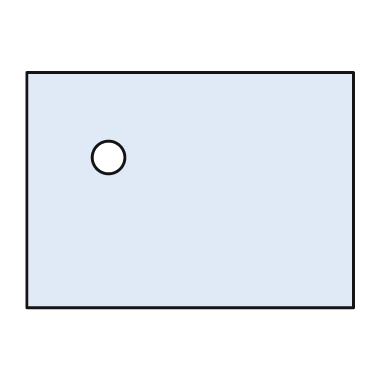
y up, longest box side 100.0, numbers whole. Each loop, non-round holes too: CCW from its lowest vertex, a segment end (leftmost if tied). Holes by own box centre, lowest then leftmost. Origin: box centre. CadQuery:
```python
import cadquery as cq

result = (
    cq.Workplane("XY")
    .moveTo(-50.0, -36.0)
    .lineTo(50.0, -36.0)
    .lineTo(50.0, 36.0)
    .lineTo(-50.0, 36.0)
    .close()
    .moveTo(-25.0, 10.0)
    .circle(5.0)
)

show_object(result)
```